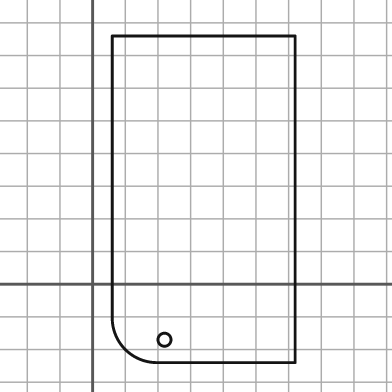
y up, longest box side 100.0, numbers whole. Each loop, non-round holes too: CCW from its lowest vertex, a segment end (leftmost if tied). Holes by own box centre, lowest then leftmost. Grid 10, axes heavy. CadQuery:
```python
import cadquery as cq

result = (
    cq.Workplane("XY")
    .moveTo(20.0, -24.0)
    .lineTo(62.0, -24.0)
    .lineTo(62.0, 76.0)
    .lineTo(6.0, 76.0)
    .lineTo(6.0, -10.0)
    .threePointArc((10.0, -20.0), (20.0, -24.0))
    .close()
    .moveTo(22.0, -17.0)
    .circle(2.0)
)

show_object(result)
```